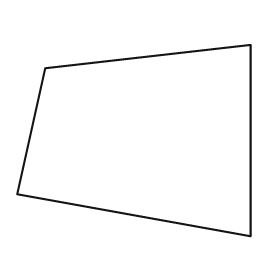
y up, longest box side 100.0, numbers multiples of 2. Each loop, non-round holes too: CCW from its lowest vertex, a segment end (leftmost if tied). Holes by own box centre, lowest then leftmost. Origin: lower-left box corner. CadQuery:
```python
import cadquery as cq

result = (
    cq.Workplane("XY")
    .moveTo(100.0, 0.0)
    .lineTo(100.0, 82.0)
    .lineTo(12.0, 72.0)
    .lineTo(0.0, 18.0)
    .close()
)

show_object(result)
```